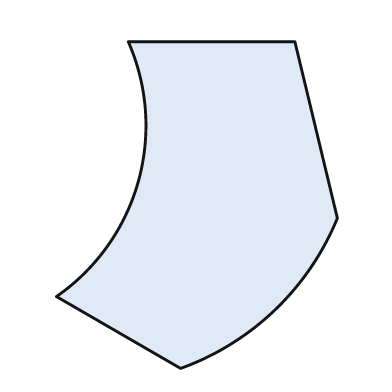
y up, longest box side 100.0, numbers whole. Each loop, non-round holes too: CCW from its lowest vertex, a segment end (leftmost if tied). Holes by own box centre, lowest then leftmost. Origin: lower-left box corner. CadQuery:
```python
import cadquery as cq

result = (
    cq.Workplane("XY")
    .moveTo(38.0, 0.0)
    .threePointArc((67.0, 18.0), (86.0, 46.0))
    .lineTo(73.0, 100.0)
    .lineTo(22.0, 100.0)
    .threePointArc((25.0, 57.0), (0.0, 22.0))
    .close()
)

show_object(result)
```